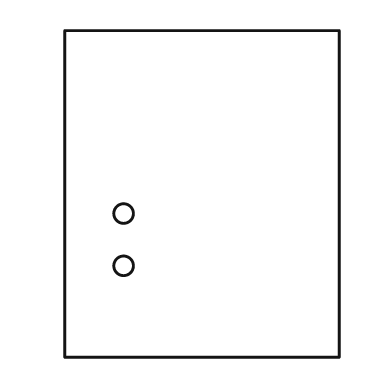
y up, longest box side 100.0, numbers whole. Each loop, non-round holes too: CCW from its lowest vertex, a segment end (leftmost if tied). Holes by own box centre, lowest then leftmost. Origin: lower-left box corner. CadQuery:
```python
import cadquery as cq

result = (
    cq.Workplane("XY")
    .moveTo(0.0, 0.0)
    .lineTo(84.0, 0.0)
    .lineTo(84.0, 100.0)
    .lineTo(0.0, 100.0)
    .close()
    .moveTo(18.0, 28.0)
    .circle(3.0)
    .moveTo(18.0, 44.0)
    .circle(3.0)
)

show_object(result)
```